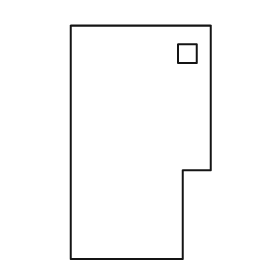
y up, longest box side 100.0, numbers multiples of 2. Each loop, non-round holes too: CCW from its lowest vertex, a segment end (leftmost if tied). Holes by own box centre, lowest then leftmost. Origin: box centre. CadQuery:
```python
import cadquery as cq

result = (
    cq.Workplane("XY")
    .moveTo(-30.0, -50.0)
    .lineTo(18.0, -50.0)
    .lineTo(18.0, -12.0)
    .lineTo(30.0, -12.0)
    .lineTo(30.0, 50.0)
    .lineTo(-30.0, 50.0)
    .close()
    .moveTo(16.0, 34.0)
    .lineTo(24.0, 34.0)
    .lineTo(24.0, 42.0)
    .lineTo(16.0, 42.0)
    .close()
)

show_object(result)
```